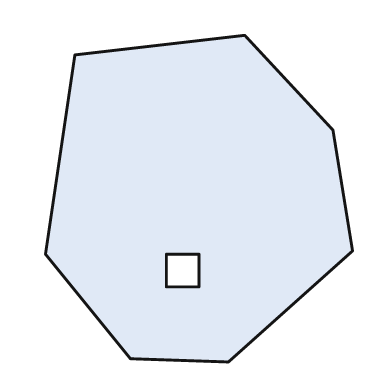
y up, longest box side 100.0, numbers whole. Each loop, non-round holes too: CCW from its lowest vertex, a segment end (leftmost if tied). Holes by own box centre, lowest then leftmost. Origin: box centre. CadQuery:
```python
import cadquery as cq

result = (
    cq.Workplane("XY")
    .moveTo(9.0, -50.0)
    .lineTo(47.0, -16.0)
    .lineTo(41.0, 21.0)
    .lineTo(14.0, 50.0)
    .lineTo(-38.0, 44.0)
    .lineTo(-47.0, -17.0)
    .lineTo(-21.0, -49.0)
    .close()
    .moveTo(-10.0, -27.0)
    .lineTo(0.0, -27.0)
    .lineTo(0.0, -17.0)
    .lineTo(-10.0, -17.0)
    .close()
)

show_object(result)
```